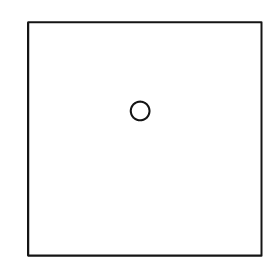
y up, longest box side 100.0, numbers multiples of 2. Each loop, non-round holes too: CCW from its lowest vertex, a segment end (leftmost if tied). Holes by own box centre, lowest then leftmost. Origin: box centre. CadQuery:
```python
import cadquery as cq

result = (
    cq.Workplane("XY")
    .moveTo(-50.0, -50.0)
    .lineTo(50.0, -50.0)
    .lineTo(50.0, 50.0)
    .lineTo(-50.0, 50.0)
    .close()
    .moveTo(-2.0, 12.0)
    .circle(4.0)
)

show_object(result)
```